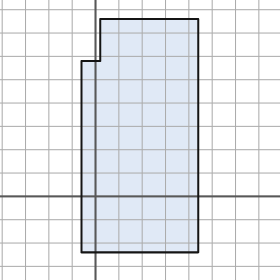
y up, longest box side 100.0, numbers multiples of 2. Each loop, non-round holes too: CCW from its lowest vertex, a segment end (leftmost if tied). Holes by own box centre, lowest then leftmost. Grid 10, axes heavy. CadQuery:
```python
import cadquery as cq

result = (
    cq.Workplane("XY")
    .moveTo(-6.0, -24.0)
    .lineTo(44.0, -24.0)
    .lineTo(44.0, 76.0)
    .lineTo(2.0, 76.0)
    .lineTo(2.0, 58.0)
    .lineTo(-6.0, 58.0)
    .close()
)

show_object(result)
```